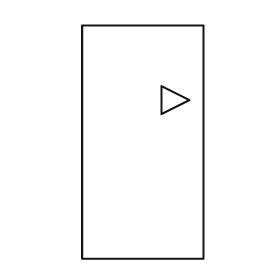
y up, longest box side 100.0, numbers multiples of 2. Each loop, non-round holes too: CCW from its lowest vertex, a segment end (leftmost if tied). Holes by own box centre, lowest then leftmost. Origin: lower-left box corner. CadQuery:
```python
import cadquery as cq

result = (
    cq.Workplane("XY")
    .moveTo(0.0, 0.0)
    .lineTo(52.0, 0.0)
    .lineTo(52.0, 100.0)
    .lineTo(0.0, 100.0)
    .close()
    .moveTo(34.0, 62.0)
    .lineTo(46.0, 68.0)
    .lineTo(34.0, 74.0)
    .close()
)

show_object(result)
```